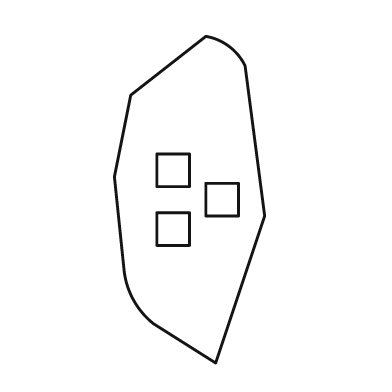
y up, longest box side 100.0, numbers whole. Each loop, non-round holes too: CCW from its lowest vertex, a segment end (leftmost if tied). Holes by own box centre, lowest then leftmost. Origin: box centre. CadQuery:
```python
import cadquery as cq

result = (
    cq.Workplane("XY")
    .moveTo(8.0, -50.0)
    .lineTo(23.0, -5.0)
    .lineTo(17.0, 41.0)
    .threePointArc((12.0, 47.0), (5.0, 50.0))
    .lineTo(-18.0, 32.0)
    .lineTo(-23.0, 7.0)
    .lineTo(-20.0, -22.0)
    .threePointArc((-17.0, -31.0), (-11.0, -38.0))
    .close()
    .moveTo(-10.0, -14.0)
    .lineTo(0.0, -14.0)
    .lineTo(0.0, -4.0)
    .lineTo(-10.0, -4.0)
    .close()
    .moveTo(5.0, -5.0)
    .lineTo(15.0, -5.0)
    .lineTo(15.0, 5.0)
    .lineTo(5.0, 5.0)
    .close()
    .moveTo(-10.0, 4.0)
    .lineTo(0.0, 4.0)
    .lineTo(0.0, 14.0)
    .lineTo(-10.0, 14.0)
    .close()
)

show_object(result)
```